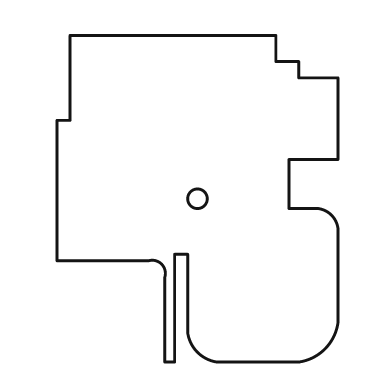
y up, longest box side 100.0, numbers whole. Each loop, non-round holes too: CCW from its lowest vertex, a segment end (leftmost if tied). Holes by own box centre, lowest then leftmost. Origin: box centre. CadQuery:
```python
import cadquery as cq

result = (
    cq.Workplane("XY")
    .moveTo(-10.0, -50.0)
    .lineTo(-7.0, -50.0)
    .lineTo(-7.0, -17.0)
    .lineTo(-3.0, -17.0)
    .lineTo(-3.0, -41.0)
    .threePointArc((0.0, -47.0), (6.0, -50.0))
    .lineTo(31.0, -50.0)
    .threePointArc((39.0, -46.0), (43.0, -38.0))
    .lineTo(43.0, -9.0)
    .threePointArc((41.0, -5.0), (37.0, -3.0))
    .lineTo(28.0, -3.0)
    .lineTo(28.0, 12.0)
    .lineTo(43.0, 12.0)
    .lineTo(43.0, 37.0)
    .lineTo(31.0, 37.0)
    .lineTo(31.0, 42.0)
    .lineTo(24.0, 42.0)
    .lineTo(24.0, 50.0)
    .lineTo(-39.0, 50.0)
    .lineTo(-39.0, 24.0)
    .lineTo(-43.0, 24.0)
    .lineTo(-43.0, -19.0)
    .lineTo(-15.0, -19.0)
    .threePointArc((-11.0, -20.0), (-10.0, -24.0))
    .close()
    .moveTo(0.0, 0.0)
    .circle(3.0)
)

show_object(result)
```